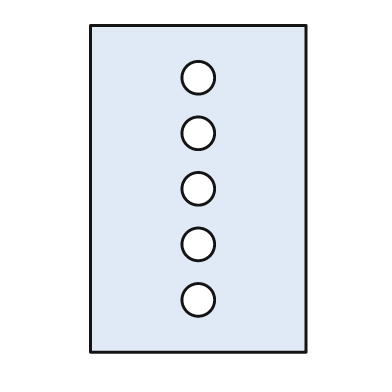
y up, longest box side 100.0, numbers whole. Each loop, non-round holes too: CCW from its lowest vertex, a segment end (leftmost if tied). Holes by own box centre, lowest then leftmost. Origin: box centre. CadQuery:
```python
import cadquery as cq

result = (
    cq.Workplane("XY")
    .moveTo(-33.0, -50.0)
    .lineTo(33.0, -50.0)
    .lineTo(33.0, 50.0)
    .lineTo(-33.0, 50.0)
    .close()
    .moveTo(0.0, -34.0)
    .circle(5.0)
    .moveTo(0.0, -17.0)
    .circle(5.0)
    .moveTo(0.0, 0.0)
    .circle(5.0)
    .moveTo(0.0, 17.0)
    .circle(5.0)
    .moveTo(0.0, 34.0)
    .circle(5.0)
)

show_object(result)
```